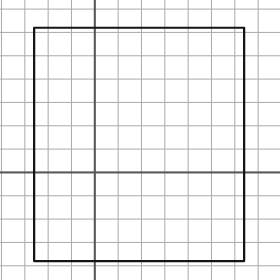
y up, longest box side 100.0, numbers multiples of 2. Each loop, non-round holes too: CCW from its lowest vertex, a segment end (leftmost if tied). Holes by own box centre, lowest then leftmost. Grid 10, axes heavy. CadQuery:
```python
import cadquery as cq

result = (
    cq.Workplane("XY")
    .moveTo(-26.0, -38.0)
    .lineTo(64.0, -38.0)
    .lineTo(64.0, 62.0)
    .lineTo(-26.0, 62.0)
    .close()
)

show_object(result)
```